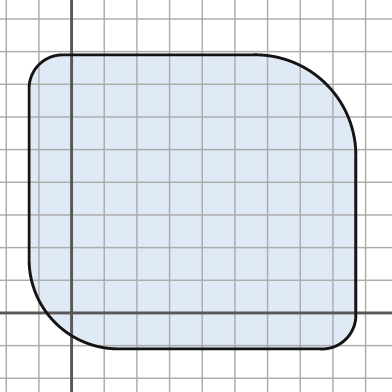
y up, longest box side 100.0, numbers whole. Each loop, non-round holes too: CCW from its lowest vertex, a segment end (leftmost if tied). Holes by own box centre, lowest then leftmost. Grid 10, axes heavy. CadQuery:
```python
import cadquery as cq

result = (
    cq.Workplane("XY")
    .moveTo(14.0, -11.0)
    .lineTo(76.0, -11.0)
    .threePointArc((84.0, -8.0), (87.0, 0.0))
    .lineTo(87.0, 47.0)
    .threePointArc((78.0, 70.0), (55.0, 79.0))
    .lineTo(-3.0, 79.0)
    .threePointArc((-10.0, 76.0), (-13.0, 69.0))
    .lineTo(-13.0, 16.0)
    .threePointArc((-5.0, -3.0), (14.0, -11.0))
    .close()
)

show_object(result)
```